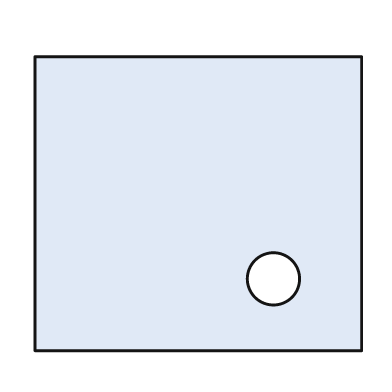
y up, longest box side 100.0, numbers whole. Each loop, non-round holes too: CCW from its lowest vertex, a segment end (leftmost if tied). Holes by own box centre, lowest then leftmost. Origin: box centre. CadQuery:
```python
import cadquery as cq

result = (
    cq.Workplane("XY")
    .moveTo(-50.0, -45.0)
    .lineTo(50.0, -45.0)
    .lineTo(50.0, 45.0)
    .lineTo(-50.0, 45.0)
    .close()
    .moveTo(23.0, -23.0)
    .circle(8.0)
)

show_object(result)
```